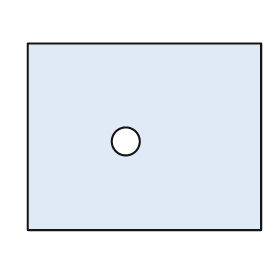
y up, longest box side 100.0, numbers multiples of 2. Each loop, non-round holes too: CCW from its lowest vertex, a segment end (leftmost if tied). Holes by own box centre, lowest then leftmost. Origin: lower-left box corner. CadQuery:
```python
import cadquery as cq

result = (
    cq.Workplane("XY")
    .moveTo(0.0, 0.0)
    .lineTo(100.0, 0.0)
    .lineTo(100.0, 80.0)
    .lineTo(0.0, 80.0)
    .close()
    .moveTo(42.0, 38.0)
    .circle(6.0)
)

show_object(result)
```